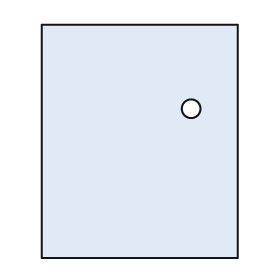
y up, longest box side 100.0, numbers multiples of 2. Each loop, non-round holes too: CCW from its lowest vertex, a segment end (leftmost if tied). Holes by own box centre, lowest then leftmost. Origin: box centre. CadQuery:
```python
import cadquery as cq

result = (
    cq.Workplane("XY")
    .moveTo(-42.0, -50.0)
    .lineTo(42.0, -50.0)
    .lineTo(42.0, 50.0)
    .lineTo(-42.0, 50.0)
    .close()
    .moveTo(22.0, 14.0)
    .circle(4.0)
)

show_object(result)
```